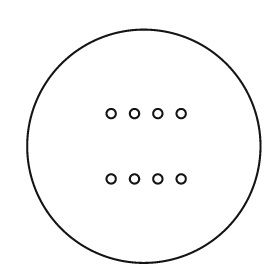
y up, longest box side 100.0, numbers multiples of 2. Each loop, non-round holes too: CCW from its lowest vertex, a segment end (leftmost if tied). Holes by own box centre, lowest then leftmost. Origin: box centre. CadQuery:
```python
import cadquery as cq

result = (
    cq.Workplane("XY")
    .moveTo(0.0, 0.0)
    .circle(50.0)
    .moveTo(-14.0, -14.0)
    .circle(2.0)
    .moveTo(-4.0, -14.0)
    .circle(2.0)
    .moveTo(6.0, -14.0)
    .circle(2.0)
    .moveTo(16.0, -14.0)
    .circle(2.0)
    .moveTo(-14.0, 14.0)
    .circle(2.0)
    .moveTo(-4.0, 14.0)
    .circle(2.0)
    .moveTo(6.0, 14.0)
    .circle(2.0)
    .moveTo(16.0, 14.0)
    .circle(2.0)
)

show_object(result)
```